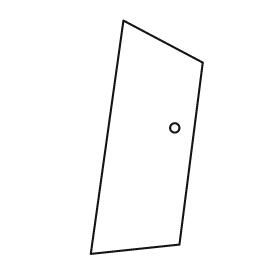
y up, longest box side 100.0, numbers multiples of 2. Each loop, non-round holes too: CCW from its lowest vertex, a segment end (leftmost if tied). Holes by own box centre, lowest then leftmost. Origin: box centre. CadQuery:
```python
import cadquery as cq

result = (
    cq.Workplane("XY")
    .moveTo(-24.0, -50.0)
    .lineTo(14.0, -46.0)
    .lineTo(24.0, 32.0)
    .lineTo(-10.0, 50.0)
    .close()
    .moveTo(12.0, 4.0)
    .circle(2.0)
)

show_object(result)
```